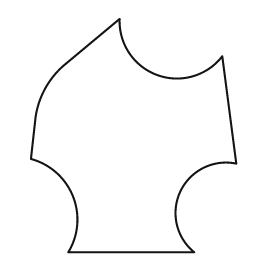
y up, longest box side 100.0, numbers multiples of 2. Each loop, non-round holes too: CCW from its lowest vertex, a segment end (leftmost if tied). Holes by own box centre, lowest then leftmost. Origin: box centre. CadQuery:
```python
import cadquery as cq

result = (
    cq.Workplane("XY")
    .moveTo(-28.0, -50.0)
    .lineTo(26.0, -50.0)
    .threePointArc((20.0, -24.0), (44.0, -12.0))
    .lineTo(38.0, 34.0)
    .threePointArc((10.0, 26.0), (-6.0, 50.0))
    .lineTo(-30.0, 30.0)
    .threePointArc((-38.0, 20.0), (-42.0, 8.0))
    .lineTo(-44.0, -10.0)
    .threePointArc((-26.0, -26.0), (-28.0, -50.0))
    .close()
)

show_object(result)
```